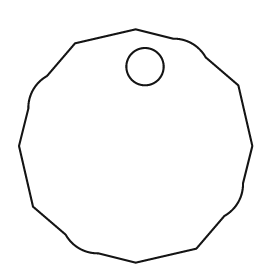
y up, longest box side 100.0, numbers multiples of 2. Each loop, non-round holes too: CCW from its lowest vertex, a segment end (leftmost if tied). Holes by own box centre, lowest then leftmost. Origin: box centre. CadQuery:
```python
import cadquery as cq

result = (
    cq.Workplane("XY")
    .moveTo(0.0, -50.0)
    .lineTo(26.0, -44.0)
    .lineTo(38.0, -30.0)
    .threePointArc((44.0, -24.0), (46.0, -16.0))
    .lineTo(50.0, 0.0)
    .lineTo(44.0, 26.0)
    .lineTo(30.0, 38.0)
    .threePointArc((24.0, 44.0), (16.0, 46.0))
    .lineTo(0.0, 50.0)
    .lineTo(-26.0, 44.0)
    .lineTo(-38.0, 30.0)
    .threePointArc((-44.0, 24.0), (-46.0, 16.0))
    .lineTo(-50.0, 0.0)
    .lineTo(-44.0, -26.0)
    .lineTo(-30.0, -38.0)
    .threePointArc((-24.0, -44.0), (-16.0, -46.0))
    .close()
    .moveTo(4.0, 34.0)
    .circle(8.0)
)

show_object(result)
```